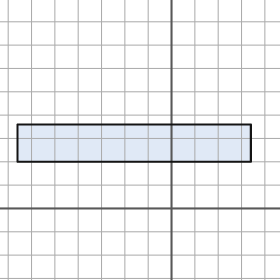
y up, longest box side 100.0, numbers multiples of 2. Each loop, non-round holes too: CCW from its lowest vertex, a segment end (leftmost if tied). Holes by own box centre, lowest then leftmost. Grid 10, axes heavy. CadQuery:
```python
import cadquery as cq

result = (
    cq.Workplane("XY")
    .moveTo(-66.0, 20.0)
    .lineTo(34.0, 20.0)
    .lineTo(34.0, 36.0)
    .lineTo(-66.0, 36.0)
    .close()
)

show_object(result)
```